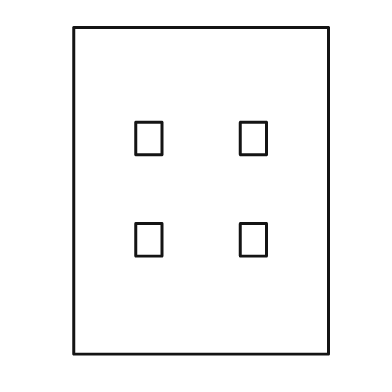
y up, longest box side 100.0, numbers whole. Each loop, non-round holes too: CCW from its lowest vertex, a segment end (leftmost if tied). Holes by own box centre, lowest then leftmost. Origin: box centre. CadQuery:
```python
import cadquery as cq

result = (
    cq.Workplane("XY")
    .moveTo(-39.0, -50.0)
    .lineTo(39.0, -50.0)
    .lineTo(39.0, 50.0)
    .lineTo(-39.0, 50.0)
    .close()
    .moveTo(-20.0, -20.0)
    .lineTo(-12.0, -20.0)
    .lineTo(-12.0, -10.0)
    .lineTo(-20.0, -10.0)
    .close()
    .moveTo(12.0, -20.0)
    .lineTo(20.0, -20.0)
    .lineTo(20.0, -10.0)
    .lineTo(12.0, -10.0)
    .close()
    .moveTo(-20.0, 11.0)
    .lineTo(-12.0, 11.0)
    .lineTo(-12.0, 21.0)
    .lineTo(-20.0, 21.0)
    .close()
    .moveTo(12.0, 11.0)
    .lineTo(20.0, 11.0)
    .lineTo(20.0, 21.0)
    .lineTo(12.0, 21.0)
    .close()
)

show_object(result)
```